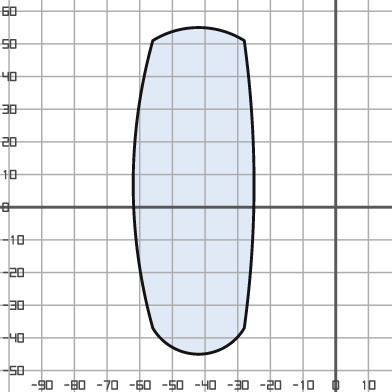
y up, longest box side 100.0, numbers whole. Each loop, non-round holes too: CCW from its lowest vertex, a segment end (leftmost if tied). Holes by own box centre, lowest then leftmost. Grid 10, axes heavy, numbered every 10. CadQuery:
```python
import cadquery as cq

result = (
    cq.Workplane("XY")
    .moveTo(-56.0, -37.0)
    .threePointArc((-42.0, -45.0), (-28.0, -37.0))
    .threePointArc((-25.0, 7.0), (-28.0, 51.0))
    .threePointArc((-42.0, 55.0), (-56.0, 51.0))
    .threePointArc((-62.0, 7.0), (-56.0, -37.0))
    .close()
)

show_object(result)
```